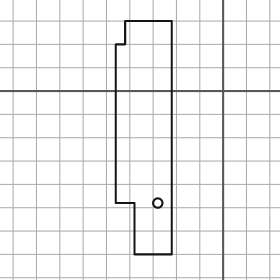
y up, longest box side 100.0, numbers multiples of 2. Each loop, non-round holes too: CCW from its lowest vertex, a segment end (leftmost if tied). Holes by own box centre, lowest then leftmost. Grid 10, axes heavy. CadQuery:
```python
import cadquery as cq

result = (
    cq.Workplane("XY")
    .moveTo(-38.0, -70.0)
    .lineTo(-22.0, -70.0)
    .lineTo(-22.0, 30.0)
    .lineTo(-42.0, 30.0)
    .lineTo(-42.0, 20.0)
    .lineTo(-46.0, 20.0)
    .lineTo(-46.0, -48.0)
    .lineTo(-38.0, -48.0)
    .close()
    .moveTo(-28.0, -48.0)
    .circle(2.0)
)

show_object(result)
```